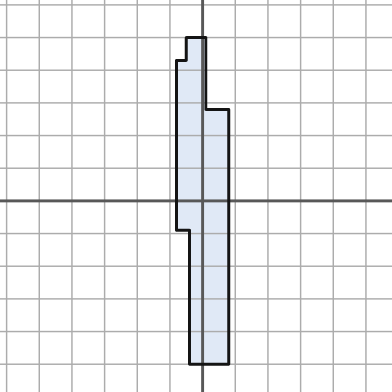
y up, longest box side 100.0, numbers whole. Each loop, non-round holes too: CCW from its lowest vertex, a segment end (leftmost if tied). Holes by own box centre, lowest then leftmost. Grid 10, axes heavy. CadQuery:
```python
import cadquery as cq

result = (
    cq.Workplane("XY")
    .moveTo(-4.0, -50.0)
    .lineTo(8.0, -50.0)
    .lineTo(8.0, 28.0)
    .lineTo(1.0, 28.0)
    .lineTo(1.0, 50.0)
    .lineTo(-5.0, 50.0)
    .lineTo(-5.0, 43.0)
    .lineTo(-8.0, 43.0)
    .lineTo(-8.0, -9.0)
    .lineTo(-4.0, -9.0)
    .close()
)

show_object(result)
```